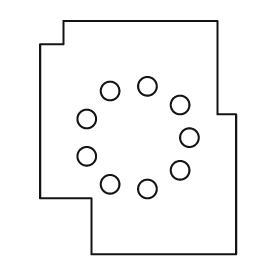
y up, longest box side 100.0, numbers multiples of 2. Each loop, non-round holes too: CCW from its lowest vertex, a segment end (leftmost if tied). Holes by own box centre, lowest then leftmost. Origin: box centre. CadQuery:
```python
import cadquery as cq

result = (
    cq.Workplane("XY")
    .moveTo(-20.0, -50.0)
    .lineTo(42.0, -50.0)
    .lineTo(42.0, 10.0)
    .lineTo(34.0, 10.0)
    .lineTo(34.0, 50.0)
    .lineTo(-32.0, 50.0)
    .lineTo(-32.0, 40.0)
    .lineTo(-42.0, 40.0)
    .lineTo(-42.0, -26.0)
    .lineTo(-20.0, -26.0)
    .close()
    .moveTo(4.0, -22.0)
    .circle(4.0)
    .moveTo(-12.0, -20.0)
    .circle(4.0)
    .moveTo(18.0, -14.0)
    .circle(4.0)
    .moveTo(-22.0, -8.0)
    .circle(4.0)
    .moveTo(22.0, 0.0)
    .circle(4.0)
    .moveTo(-22.0, 8.0)
    .circle(4.0)
    .moveTo(18.0, 14.0)
    .circle(4.0)
    .moveTo(-12.0, 20.0)
    .circle(4.0)
    .moveTo(4.0, 22.0)
    .circle(4.0)
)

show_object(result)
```